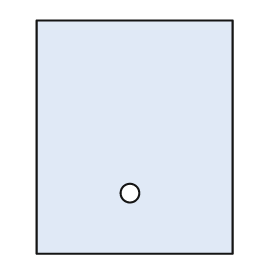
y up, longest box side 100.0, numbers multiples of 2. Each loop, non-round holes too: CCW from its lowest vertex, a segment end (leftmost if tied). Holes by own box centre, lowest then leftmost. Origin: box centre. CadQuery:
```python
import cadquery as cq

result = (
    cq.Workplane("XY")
    .moveTo(-42.0, -50.0)
    .lineTo(42.0, -50.0)
    .lineTo(42.0, 50.0)
    .lineTo(-42.0, 50.0)
    .close()
    .moveTo(-2.0, -24.0)
    .circle(4.0)
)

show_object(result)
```